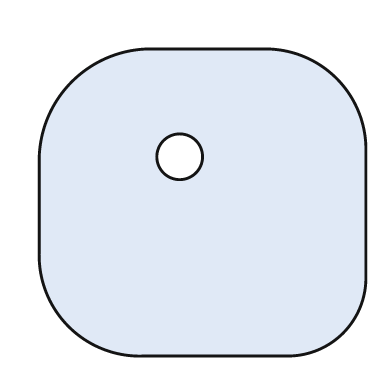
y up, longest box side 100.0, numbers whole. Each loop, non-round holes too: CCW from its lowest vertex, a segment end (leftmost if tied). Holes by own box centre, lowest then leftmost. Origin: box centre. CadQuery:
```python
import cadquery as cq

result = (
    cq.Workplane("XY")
    .moveTo(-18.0, -47.0)
    .lineTo(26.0, -47.0)
    .threePointArc((43.0, -40.0), (50.0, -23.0))
    .lineTo(50.0, 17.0)
    .threePointArc((41.0, 38.0), (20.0, 47.0))
    .lineTo(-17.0, 47.0)
    .threePointArc((-40.0, 37.0), (-50.0, 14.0))
    .lineTo(-50.0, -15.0)
    .threePointArc((-41.0, -38.0), (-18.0, -47.0))
    .close()
    .moveTo(-7.0, 14.0)
    .circle(7.0)
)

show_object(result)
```